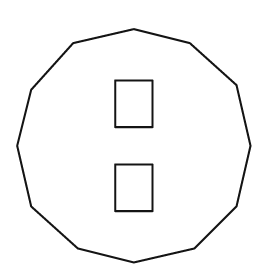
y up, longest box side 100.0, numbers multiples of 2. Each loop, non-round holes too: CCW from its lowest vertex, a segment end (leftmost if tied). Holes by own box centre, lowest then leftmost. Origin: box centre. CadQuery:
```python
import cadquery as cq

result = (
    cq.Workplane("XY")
    .moveTo(0.0, -50.0)
    .lineTo(26.0, -44.0)
    .lineTo(44.0, -26.0)
    .lineTo(50.0, 0.0)
    .lineTo(44.0, 26.0)
    .lineTo(24.0, 44.0)
    .lineTo(0.0, 50.0)
    .lineTo(-26.0, 44.0)
    .lineTo(-44.0, 24.0)
    .lineTo(-50.0, 0.0)
    .lineTo(-44.0, -26.0)
    .lineTo(-24.0, -44.0)
    .close()
    .moveTo(-8.0, -28.0)
    .lineTo(8.0, -28.0)
    .lineTo(8.0, -8.0)
    .lineTo(-8.0, -8.0)
    .close()
    .moveTo(-8.0, 8.0)
    .lineTo(8.0, 8.0)
    .lineTo(8.0, 28.0)
    .lineTo(-8.0, 28.0)
    .close()
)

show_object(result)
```